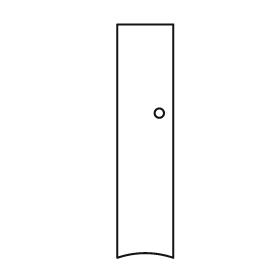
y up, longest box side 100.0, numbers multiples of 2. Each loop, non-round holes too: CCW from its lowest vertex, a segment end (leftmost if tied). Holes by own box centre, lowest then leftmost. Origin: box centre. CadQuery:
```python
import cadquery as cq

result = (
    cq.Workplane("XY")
    .moveTo(-12.0, -50.0)
    .threePointArc((0.0, -48.0), (12.0, -50.0))
    .lineTo(12.0, 50.0)
    .lineTo(-12.0, 50.0)
    .close()
    .moveTo(6.0, 12.0)
    .circle(2.0)
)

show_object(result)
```